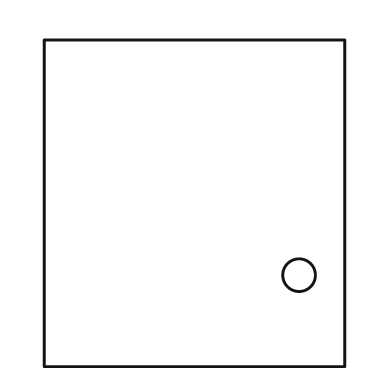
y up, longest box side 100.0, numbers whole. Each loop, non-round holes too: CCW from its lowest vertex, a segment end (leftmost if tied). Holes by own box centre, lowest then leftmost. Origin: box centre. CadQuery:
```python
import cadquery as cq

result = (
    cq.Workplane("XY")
    .moveTo(-46.0, -50.0)
    .lineTo(46.0, -50.0)
    .lineTo(46.0, 50.0)
    .lineTo(-46.0, 50.0)
    .close()
    .moveTo(32.0, -22.0)
    .circle(5.0)
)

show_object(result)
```